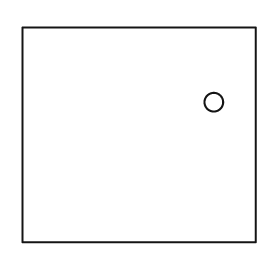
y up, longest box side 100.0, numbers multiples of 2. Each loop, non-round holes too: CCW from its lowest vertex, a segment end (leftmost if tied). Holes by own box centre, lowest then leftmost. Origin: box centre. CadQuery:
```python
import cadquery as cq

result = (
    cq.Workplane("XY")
    .moveTo(-50.0, -46.0)
    .lineTo(50.0, -46.0)
    .lineTo(50.0, 46.0)
    .lineTo(-50.0, 46.0)
    .close()
    .moveTo(32.0, 14.0)
    .circle(4.0)
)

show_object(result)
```